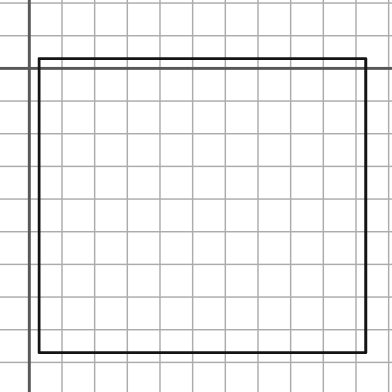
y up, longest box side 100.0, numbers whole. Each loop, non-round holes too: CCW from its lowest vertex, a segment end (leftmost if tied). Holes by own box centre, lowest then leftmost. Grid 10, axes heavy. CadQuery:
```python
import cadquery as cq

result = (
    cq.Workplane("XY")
    .moveTo(3.0, -87.0)
    .lineTo(103.0, -87.0)
    .lineTo(103.0, 3.0)
    .lineTo(3.0, 3.0)
    .close()
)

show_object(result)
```